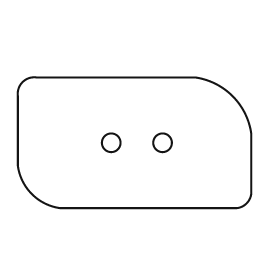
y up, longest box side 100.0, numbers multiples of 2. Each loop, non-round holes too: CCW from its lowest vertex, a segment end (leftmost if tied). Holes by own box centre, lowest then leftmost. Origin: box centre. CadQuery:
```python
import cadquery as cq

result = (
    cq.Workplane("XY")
    .moveTo(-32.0, -28.0)
    .lineTo(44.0, -28.0)
    .threePointArc((48.0, -26.0), (50.0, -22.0))
    .lineTo(50.0, 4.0)
    .threePointArc((42.0, 20.0), (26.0, 28.0))
    .lineTo(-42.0, 28.0)
    .threePointArc((-48.0, 26.0), (-50.0, 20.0))
    .lineTo(-50.0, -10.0)
    .threePointArc((-44.0, -22.0), (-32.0, -28.0))
    .close()
    .moveTo(-10.0, 0.0)
    .circle(4.0)
    .moveTo(12.0, 0.0)
    .circle(4.0)
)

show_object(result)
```